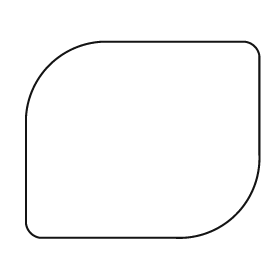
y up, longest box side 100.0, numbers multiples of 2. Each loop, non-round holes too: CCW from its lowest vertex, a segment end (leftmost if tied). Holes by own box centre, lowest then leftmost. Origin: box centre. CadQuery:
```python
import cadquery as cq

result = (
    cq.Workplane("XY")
    .moveTo(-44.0, -42.0)
    .lineTo(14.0, -42.0)
    .threePointArc((40.0, -32.0), (50.0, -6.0))
    .lineTo(50.0, 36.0)
    .threePointArc((48.0, 40.0), (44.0, 42.0))
    .lineTo(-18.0, 42.0)
    .threePointArc((-40.0, 32.0), (-50.0, 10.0))
    .lineTo(-50.0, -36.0)
    .threePointArc((-48.0, -40.0), (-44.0, -42.0))
    .close()
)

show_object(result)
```